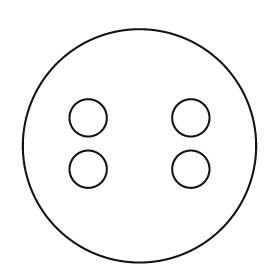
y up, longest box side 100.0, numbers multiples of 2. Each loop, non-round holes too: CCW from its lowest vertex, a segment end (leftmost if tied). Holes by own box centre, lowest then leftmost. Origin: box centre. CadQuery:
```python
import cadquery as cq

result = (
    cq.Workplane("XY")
    .moveTo(0.0, 0.0)
    .circle(50.0)
    .moveTo(-22.0, -10.0)
    .circle(8.0)
    .moveTo(22.0, -10.0)
    .circle(8.0)
    .moveTo(-22.0, 12.0)
    .circle(8.0)
    .moveTo(22.0, 12.0)
    .circle(8.0)
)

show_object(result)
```